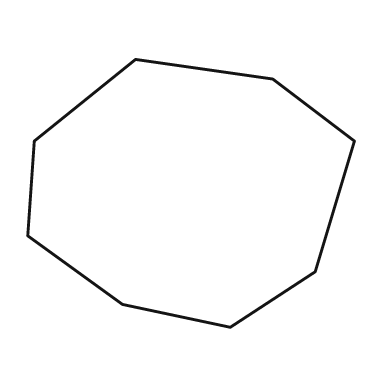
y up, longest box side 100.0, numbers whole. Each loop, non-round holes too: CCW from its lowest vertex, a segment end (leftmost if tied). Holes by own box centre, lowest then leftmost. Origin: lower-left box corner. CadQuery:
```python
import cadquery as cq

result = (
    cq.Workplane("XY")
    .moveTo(62.0, 0.0)
    .lineTo(88.0, 17.0)
    .lineTo(100.0, 57.0)
    .lineTo(75.0, 76.0)
    .lineTo(33.0, 82.0)
    .lineTo(2.0, 57.0)
    .lineTo(0.0, 28.0)
    .lineTo(29.0, 7.0)
    .close()
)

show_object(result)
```